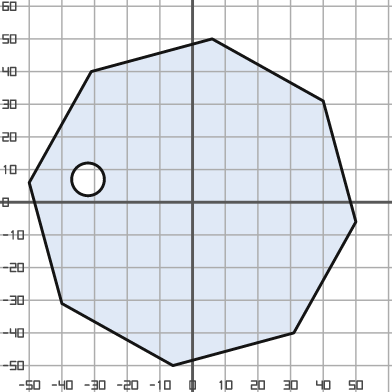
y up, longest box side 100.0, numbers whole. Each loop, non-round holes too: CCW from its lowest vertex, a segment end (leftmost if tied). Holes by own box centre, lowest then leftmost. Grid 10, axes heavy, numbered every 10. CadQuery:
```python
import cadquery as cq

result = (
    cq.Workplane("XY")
    .moveTo(-6.0, -50.0)
    .lineTo(31.0, -40.0)
    .lineTo(50.0, -6.0)
    .lineTo(40.0, 31.0)
    .lineTo(6.0, 50.0)
    .lineTo(-31.0, 40.0)
    .lineTo(-50.0, 6.0)
    .lineTo(-40.0, -31.0)
    .close()
    .moveTo(-32.0, 7.0)
    .circle(5.0)
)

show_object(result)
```